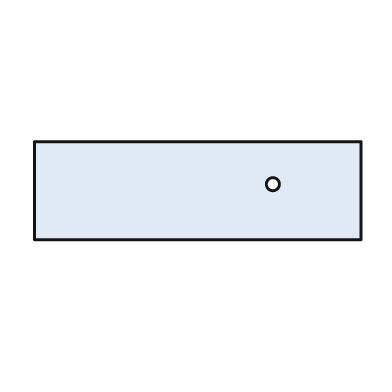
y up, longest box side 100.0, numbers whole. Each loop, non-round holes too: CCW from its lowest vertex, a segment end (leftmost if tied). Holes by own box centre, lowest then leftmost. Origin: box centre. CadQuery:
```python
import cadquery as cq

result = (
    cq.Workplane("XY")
    .moveTo(-50.0, -15.0)
    .lineTo(50.0, -15.0)
    .lineTo(50.0, 15.0)
    .lineTo(-50.0, 15.0)
    .close()
    .moveTo(23.0, 2.0)
    .circle(2.0)
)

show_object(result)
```